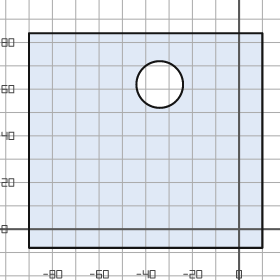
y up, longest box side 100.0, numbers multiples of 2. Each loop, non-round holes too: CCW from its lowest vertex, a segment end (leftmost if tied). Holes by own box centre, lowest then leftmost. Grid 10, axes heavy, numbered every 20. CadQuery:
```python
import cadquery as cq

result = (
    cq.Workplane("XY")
    .moveTo(-90.0, -8.0)
    .lineTo(10.0, -8.0)
    .lineTo(10.0, 84.0)
    .lineTo(-90.0, 84.0)
    .close()
    .moveTo(-34.0, 62.0)
    .circle(10.0)
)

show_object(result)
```